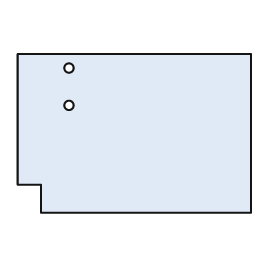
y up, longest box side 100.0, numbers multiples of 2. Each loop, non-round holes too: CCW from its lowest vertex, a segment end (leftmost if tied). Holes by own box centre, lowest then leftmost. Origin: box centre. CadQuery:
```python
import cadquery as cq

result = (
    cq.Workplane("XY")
    .moveTo(-40.0, -34.0)
    .lineTo(50.0, -34.0)
    .lineTo(50.0, 34.0)
    .lineTo(-50.0, 34.0)
    .lineTo(-50.0, -22.0)
    .lineTo(-40.0, -22.0)
    .close()
    .moveTo(-28.0, 12.0)
    .circle(2.0)
    .moveTo(-28.0, 28.0)
    .circle(2.0)
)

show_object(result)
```